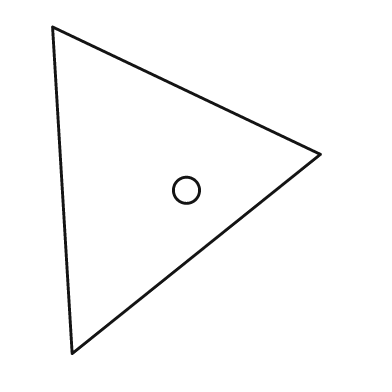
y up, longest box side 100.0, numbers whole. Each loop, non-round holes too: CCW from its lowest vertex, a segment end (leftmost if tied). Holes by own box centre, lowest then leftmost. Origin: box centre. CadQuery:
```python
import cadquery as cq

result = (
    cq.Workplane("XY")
    .moveTo(-35.0, -50.0)
    .lineTo(41.0, 11.0)
    .lineTo(-41.0, 50.0)
    .close()
    .moveTo(0.0, 0.0)
    .circle(4.0)
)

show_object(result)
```